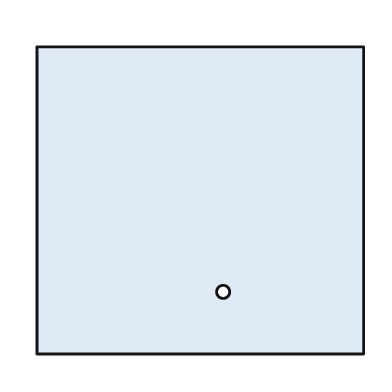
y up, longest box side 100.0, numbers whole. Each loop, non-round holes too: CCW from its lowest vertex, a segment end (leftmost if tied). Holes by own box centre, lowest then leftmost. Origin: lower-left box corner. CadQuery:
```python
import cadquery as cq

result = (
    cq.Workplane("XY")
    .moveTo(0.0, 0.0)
    .lineTo(100.0, 0.0)
    .lineTo(100.0, 94.0)
    .lineTo(0.0, 94.0)
    .close()
    .moveTo(57.0, 19.0)
    .circle(2.0)
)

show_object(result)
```